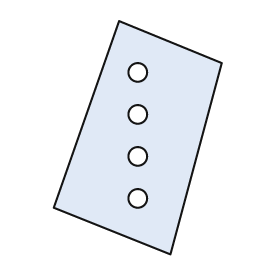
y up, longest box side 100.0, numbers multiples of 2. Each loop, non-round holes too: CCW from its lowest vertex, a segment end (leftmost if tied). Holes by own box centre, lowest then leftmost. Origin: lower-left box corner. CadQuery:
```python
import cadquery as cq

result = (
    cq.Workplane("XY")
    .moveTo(50.0, 0.0)
    .lineTo(72.0, 82.0)
    .lineTo(28.0, 100.0)
    .lineTo(0.0, 20.0)
    .close()
    .moveTo(36.0, 24.0)
    .circle(4.0)
    .moveTo(36.0, 42.0)
    .circle(4.0)
    .moveTo(36.0, 60.0)
    .circle(4.0)
    .moveTo(36.0, 78.0)
    .circle(4.0)
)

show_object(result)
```